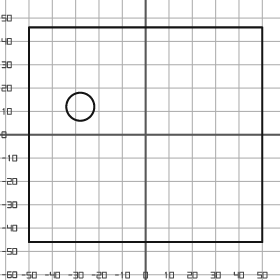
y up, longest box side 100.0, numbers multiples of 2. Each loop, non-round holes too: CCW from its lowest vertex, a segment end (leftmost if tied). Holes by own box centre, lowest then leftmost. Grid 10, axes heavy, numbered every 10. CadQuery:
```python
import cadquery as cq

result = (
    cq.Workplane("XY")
    .moveTo(-50.0, -46.0)
    .lineTo(50.0, -46.0)
    .lineTo(50.0, 46.0)
    .lineTo(-50.0, 46.0)
    .close()
    .moveTo(-28.0, 12.0)
    .circle(6.0)
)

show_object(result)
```